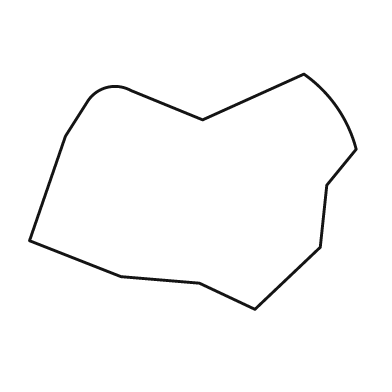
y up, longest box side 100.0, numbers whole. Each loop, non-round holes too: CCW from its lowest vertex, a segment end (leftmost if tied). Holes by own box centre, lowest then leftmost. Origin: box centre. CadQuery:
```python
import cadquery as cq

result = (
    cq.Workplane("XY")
    .moveTo(19.0, -36.0)
    .lineTo(39.0, -17.0)
    .lineTo(41.0, 2.0)
    .lineTo(50.0, 13.0)
    .threePointArc((44.0, 26.0), (34.0, 36.0))
    .lineTo(3.0, 22.0)
    .lineTo(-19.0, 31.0)
    .threePointArc((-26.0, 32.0), (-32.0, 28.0))
    .lineTo(-39.0, 17.0)
    .lineTo(-50.0, -15.0)
    .lineTo(-22.0, -26.0)
    .lineTo(2.0, -28.0)
    .close()
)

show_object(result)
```